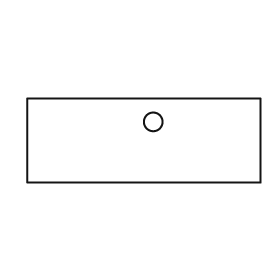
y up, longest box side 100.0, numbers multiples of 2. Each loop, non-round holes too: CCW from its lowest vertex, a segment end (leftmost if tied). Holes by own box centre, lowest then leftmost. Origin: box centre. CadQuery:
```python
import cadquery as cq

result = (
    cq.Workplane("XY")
    .moveTo(-50.0, -18.0)
    .lineTo(50.0, -18.0)
    .lineTo(50.0, 18.0)
    .lineTo(-50.0, 18.0)
    .close()
    .moveTo(4.0, 8.0)
    .circle(4.0)
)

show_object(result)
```